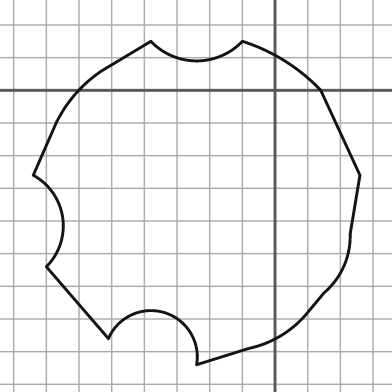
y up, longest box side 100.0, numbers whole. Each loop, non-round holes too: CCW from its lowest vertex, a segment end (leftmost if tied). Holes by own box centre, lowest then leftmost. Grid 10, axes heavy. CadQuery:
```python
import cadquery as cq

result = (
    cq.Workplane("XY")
    .moveTo(-24.0, -84.0)
    .lineTo(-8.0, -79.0)
    .threePointArc((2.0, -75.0), (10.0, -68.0))
    .lineTo(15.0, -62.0)
    .threePointArc((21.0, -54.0), (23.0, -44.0))
    .lineTo(26.0, -26.0)
    .lineTo(14.0, 0.0)
    .threePointArc((3.0, 9.0), (-10.0, 15.0))
    .threePointArc((-24.0, 9.0), (-38.0, 15.0))
    .lineTo(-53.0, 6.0)
    .threePointArc((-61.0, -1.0), (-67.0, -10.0))
    .lineTo(-74.0, -26.0)
    .threePointArc((-65.0, -39.0), (-70.0, -54.0))
    .lineTo(-51.0, -76.0)
    .threePointArc((-34.0, -68.0), (-24.0, -84.0))
    .close()
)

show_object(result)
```